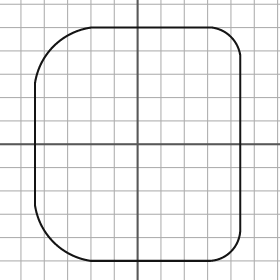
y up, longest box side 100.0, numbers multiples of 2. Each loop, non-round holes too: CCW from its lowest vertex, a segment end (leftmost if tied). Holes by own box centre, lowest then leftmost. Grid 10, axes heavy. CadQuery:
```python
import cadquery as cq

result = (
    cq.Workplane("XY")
    .moveTo(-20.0, -50.0)
    .lineTo(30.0, -50.0)
    .threePointArc((40.0, -46.0), (44.0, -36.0))
    .lineTo(44.0, 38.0)
    .threePointArc((40.0, 46.0), (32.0, 50.0))
    .lineTo(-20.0, 50.0)
    .threePointArc((-36.0, 42.0), (-44.0, 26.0))
    .lineTo(-44.0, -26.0)
    .threePointArc((-36.0, -42.0), (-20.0, -50.0))
    .close()
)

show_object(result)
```